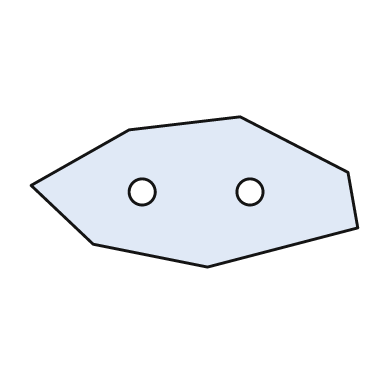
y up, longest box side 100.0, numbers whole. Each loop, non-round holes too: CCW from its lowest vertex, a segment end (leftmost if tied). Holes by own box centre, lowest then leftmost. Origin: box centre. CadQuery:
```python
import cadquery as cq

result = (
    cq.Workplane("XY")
    .moveTo(4.0, -23.0)
    .lineTo(50.0, -11.0)
    .lineTo(47.0, 6.0)
    .lineTo(14.0, 23.0)
    .lineTo(-20.0, 19.0)
    .lineTo(-50.0, 2.0)
    .lineTo(-31.0, -16.0)
    .close()
    .moveTo(-16.0, 0.0)
    .circle(4.0)
    .moveTo(17.0, 0.0)
    .circle(4.0)
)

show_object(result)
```